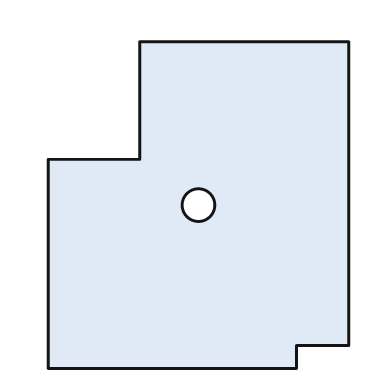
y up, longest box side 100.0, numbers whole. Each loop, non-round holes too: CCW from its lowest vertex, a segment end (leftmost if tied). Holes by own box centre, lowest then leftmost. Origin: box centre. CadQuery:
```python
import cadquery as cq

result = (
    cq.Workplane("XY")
    .moveTo(-46.0, -50.0)
    .lineTo(30.0, -50.0)
    .lineTo(30.0, -43.0)
    .lineTo(46.0, -43.0)
    .lineTo(46.0, 50.0)
    .lineTo(-18.0, 50.0)
    .lineTo(-18.0, 14.0)
    .lineTo(-46.0, 14.0)
    .close()
    .moveTo(0.0, 0.0)
    .circle(5.0)
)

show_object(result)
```